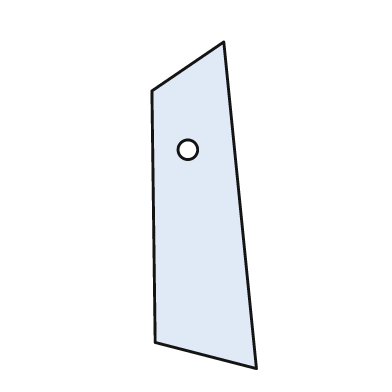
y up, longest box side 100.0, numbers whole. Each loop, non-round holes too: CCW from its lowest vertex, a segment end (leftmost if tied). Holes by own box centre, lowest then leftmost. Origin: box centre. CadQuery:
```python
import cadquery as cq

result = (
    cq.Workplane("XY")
    .moveTo(16.0, -50.0)
    .lineTo(6.0, 50.0)
    .lineTo(-16.0, 35.0)
    .lineTo(-15.0, -42.0)
    .close()
    .moveTo(-5.0, 17.0)
    .circle(3.0)
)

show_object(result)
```